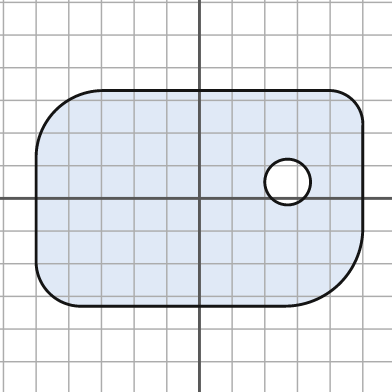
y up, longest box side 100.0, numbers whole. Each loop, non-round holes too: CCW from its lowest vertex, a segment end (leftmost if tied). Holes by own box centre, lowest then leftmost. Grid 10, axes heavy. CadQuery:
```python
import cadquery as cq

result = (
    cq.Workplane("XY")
    .moveTo(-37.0, -33.0)
    .lineTo(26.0, -33.0)
    .threePointArc((43.0, -26.0), (50.0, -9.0))
    .lineTo(50.0, 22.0)
    .threePointArc((47.0, 30.0), (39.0, 33.0))
    .lineTo(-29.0, 33.0)
    .threePointArc((-44.0, 27.0), (-50.0, 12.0))
    .lineTo(-50.0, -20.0)
    .threePointArc((-46.0, -29.0), (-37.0, -33.0))
    .close()
    .moveTo(27.0, 5.0)
    .circle(7.0)
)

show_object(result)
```